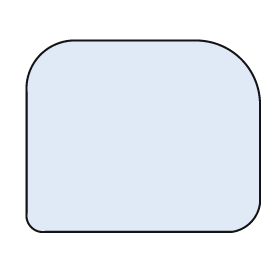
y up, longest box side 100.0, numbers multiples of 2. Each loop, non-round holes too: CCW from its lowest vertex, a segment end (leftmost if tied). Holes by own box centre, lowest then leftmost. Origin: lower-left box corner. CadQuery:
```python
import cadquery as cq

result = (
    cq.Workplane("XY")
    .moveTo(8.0, 0.0)
    .lineTo(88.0, 0.0)
    .threePointArc((96.0, 4.0), (100.0, 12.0))
    .lineTo(100.0, 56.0)
    .threePointArc((92.0, 74.0), (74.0, 82.0))
    .lineTo(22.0, 82.0)
    .threePointArc((6.0, 76.0), (0.0, 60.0))
    .lineTo(0.0, 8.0)
    .threePointArc((2.0, 2.0), (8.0, 0.0))
    .close()
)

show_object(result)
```